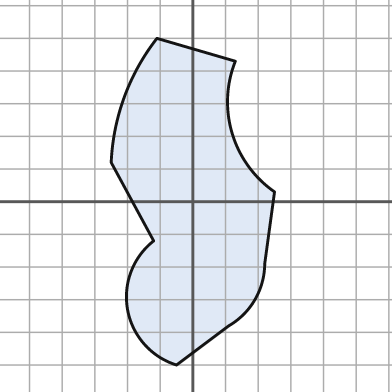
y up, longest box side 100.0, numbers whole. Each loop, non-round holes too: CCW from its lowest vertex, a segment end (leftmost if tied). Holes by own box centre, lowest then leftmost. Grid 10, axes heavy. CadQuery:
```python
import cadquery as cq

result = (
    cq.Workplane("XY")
    .moveTo(-5.0, -50.0)
    .lineTo(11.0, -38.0)
    .threePointArc((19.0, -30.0), (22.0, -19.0))
    .lineTo(25.0, 3.0)
    .threePointArc((12.0, 21.0), (13.0, 43.0))
    .lineTo(-11.0, 50.0)
    .threePointArc((-21.0, 32.0), (-25.0, 12.0))
    .lineTo(-12.0, -12.0)
    .threePointArc((-20.0, -33.0), (-5.0, -50.0))
    .close()
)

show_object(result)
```